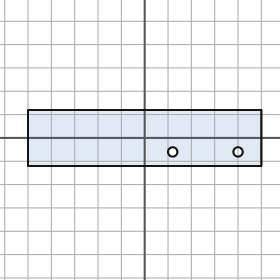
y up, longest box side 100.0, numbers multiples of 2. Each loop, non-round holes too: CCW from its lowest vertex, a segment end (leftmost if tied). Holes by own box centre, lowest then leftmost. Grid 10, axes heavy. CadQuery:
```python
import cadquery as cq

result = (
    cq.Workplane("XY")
    .moveTo(-50.0, -12.0)
    .lineTo(50.0, -12.0)
    .lineTo(50.0, 12.0)
    .lineTo(-50.0, 12.0)
    .close()
    .moveTo(12.0, -6.0)
    .circle(2.0)
    .moveTo(40.0, -6.0)
    .circle(2.0)
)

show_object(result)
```